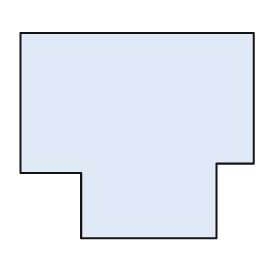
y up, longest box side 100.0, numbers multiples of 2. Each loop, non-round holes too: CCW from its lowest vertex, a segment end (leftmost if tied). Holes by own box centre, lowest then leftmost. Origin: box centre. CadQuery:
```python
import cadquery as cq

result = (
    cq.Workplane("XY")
    .moveTo(-24.0, -44.0)
    .lineTo(34.0, -44.0)
    .lineTo(34.0, -12.0)
    .lineTo(50.0, -12.0)
    .lineTo(50.0, 44.0)
    .lineTo(-50.0, 44.0)
    .lineTo(-50.0, -16.0)
    .lineTo(-24.0, -16.0)
    .close()
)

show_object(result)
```